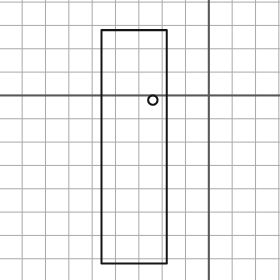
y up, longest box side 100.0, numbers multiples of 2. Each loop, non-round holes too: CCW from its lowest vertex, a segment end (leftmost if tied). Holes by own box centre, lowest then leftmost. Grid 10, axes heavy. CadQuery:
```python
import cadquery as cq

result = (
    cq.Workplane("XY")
    .moveTo(-46.0, -72.0)
    .lineTo(-18.0, -72.0)
    .lineTo(-18.0, 28.0)
    .lineTo(-46.0, 28.0)
    .close()
    .moveTo(-24.0, -2.0)
    .circle(2.0)
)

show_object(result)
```